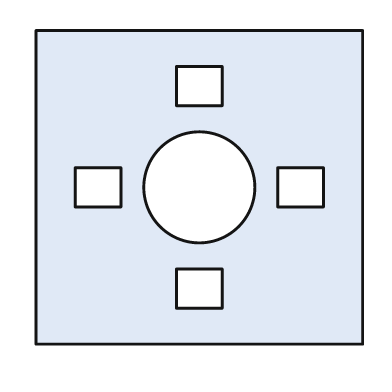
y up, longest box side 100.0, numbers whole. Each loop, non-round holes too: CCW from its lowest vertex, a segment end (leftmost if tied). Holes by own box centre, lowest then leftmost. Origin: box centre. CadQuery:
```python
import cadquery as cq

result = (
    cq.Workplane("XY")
    .moveTo(-50.0, -48.0)
    .lineTo(50.0, -48.0)
    .lineTo(50.0, 48.0)
    .lineTo(-50.0, 48.0)
    .close()
    .moveTo(-7.0, -37.0)
    .lineTo(7.0, -37.0)
    .lineTo(7.0, -25.0)
    .lineTo(-7.0, -25.0)
    .close()
    .moveTo(-38.0, -6.0)
    .lineTo(-24.0, -6.0)
    .lineTo(-24.0, 6.0)
    .lineTo(-38.0, 6.0)
    .close()
    .moveTo(0.0, 0.0)
    .circle(17.0)
    .moveTo(24.0, -6.0)
    .lineTo(38.0, -6.0)
    .lineTo(38.0, 6.0)
    .lineTo(24.0, 6.0)
    .close()
    .moveTo(-7.0, 25.0)
    .lineTo(7.0, 25.0)
    .lineTo(7.0, 37.0)
    .lineTo(-7.0, 37.0)
    .close()
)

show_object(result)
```